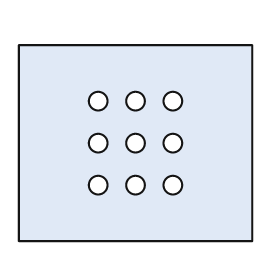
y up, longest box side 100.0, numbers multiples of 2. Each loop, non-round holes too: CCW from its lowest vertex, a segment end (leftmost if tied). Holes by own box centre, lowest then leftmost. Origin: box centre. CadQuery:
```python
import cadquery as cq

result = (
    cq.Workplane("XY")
    .moveTo(-50.0, -42.0)
    .lineTo(50.0, -42.0)
    .lineTo(50.0, 42.0)
    .lineTo(-50.0, 42.0)
    .close()
    .moveTo(-16.0, -18.0)
    .circle(4.0)
    .moveTo(0.0, -18.0)
    .circle(4.0)
    .moveTo(16.0, -18.0)
    .circle(4.0)
    .moveTo(-16.0, 0.0)
    .circle(4.0)
    .moveTo(0.0, 0.0)
    .circle(4.0)
    .moveTo(16.0, 0.0)
    .circle(4.0)
    .moveTo(-16.0, 18.0)
    .circle(4.0)
    .moveTo(0.0, 18.0)
    .circle(4.0)
    .moveTo(16.0, 18.0)
    .circle(4.0)
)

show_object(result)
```